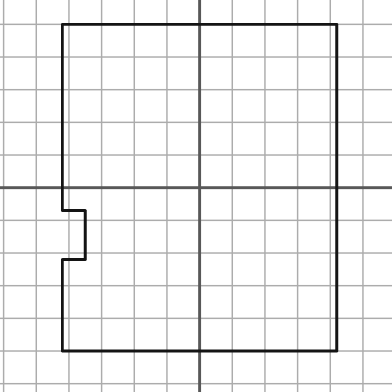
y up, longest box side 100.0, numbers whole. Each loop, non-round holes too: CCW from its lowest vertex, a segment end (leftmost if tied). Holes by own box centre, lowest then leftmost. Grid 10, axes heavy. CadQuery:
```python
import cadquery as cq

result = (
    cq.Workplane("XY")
    .moveTo(-42.0, -50.0)
    .lineTo(42.0, -50.0)
    .lineTo(42.0, 50.0)
    .lineTo(-42.0, 50.0)
    .lineTo(-42.0, -7.0)
    .lineTo(-35.0, -7.0)
    .lineTo(-35.0, -22.0)
    .lineTo(-42.0, -22.0)
    .close()
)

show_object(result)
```